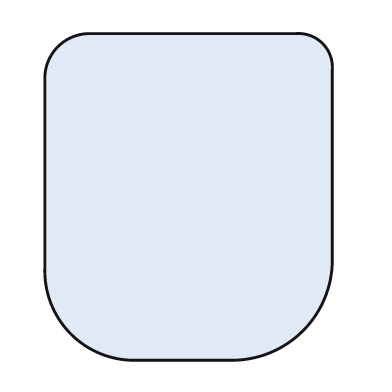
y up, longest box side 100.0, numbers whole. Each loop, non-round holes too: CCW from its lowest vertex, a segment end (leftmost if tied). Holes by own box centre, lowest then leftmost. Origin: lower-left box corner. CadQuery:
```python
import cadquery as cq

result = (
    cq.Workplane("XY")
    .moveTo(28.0, 0.0)
    .lineTo(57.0, 0.0)
    .threePointArc((79.0, 9.0), (88.0, 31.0))
    .lineTo(88.0, 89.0)
    .threePointArc((85.0, 97.0), (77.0, 100.0))
    .lineTo(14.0, 100.0)
    .threePointArc((4.0, 96.0), (0.0, 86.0))
    .lineTo(0.0, 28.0)
    .threePointArc((8.0, 8.0), (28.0, 0.0))
    .close()
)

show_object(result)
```